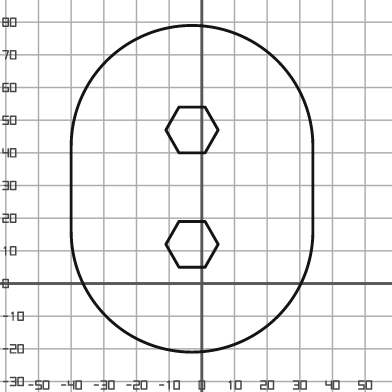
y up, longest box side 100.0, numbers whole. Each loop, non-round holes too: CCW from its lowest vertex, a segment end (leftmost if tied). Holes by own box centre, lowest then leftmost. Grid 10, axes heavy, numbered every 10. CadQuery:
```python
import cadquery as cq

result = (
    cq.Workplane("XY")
    .moveTo(-40.0, 16.0)
    .threePointArc((-3.0, -21.0), (34.0, 16.0))
    .lineTo(34.0, 42.0)
    .threePointArc((-3.0, 79.0), (-40.0, 42.0))
    .close()
    .moveTo(-7.0, 5.0)
    .lineTo(1.0, 5.0)
    .lineTo(5.0, 12.0)
    .lineTo(1.0, 19.0)
    .lineTo(-7.0, 19.0)
    .lineTo(-11.0, 12.0)
    .close()
    .moveTo(-7.0, 40.0)
    .lineTo(1.0, 40.0)
    .lineTo(5.0, 47.0)
    .lineTo(1.0, 54.0)
    .lineTo(-7.0, 54.0)
    .lineTo(-11.0, 47.0)
    .close()
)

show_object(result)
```